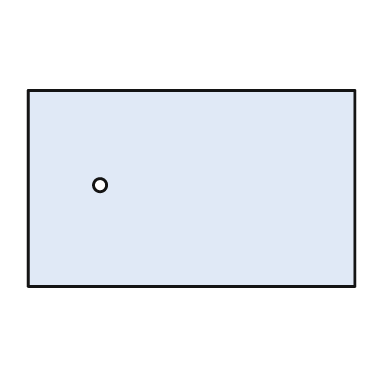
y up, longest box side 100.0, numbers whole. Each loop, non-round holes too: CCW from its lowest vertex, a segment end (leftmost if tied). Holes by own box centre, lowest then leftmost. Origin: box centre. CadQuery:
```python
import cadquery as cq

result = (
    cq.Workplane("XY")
    .moveTo(-50.0, -30.0)
    .lineTo(50.0, -30.0)
    .lineTo(50.0, 30.0)
    .lineTo(-50.0, 30.0)
    .close()
    .moveTo(-28.0, 1.0)
    .circle(2.0)
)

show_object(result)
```